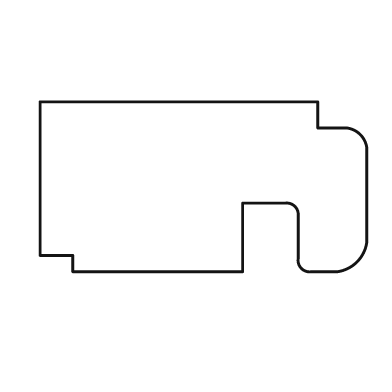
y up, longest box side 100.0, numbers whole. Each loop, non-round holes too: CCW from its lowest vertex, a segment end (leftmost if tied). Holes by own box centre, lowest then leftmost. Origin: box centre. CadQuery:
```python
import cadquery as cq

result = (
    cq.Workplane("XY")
    .moveTo(-40.0, -26.0)
    .lineTo(12.0, -26.0)
    .lineTo(12.0, -5.0)
    .lineTo(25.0, -5.0)
    .threePointArc((28.0, -6.0), (29.0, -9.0))
    .lineTo(29.0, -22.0)
    .threePointArc((30.0, -25.0), (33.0, -26.0))
    .lineTo(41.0, -26.0)
    .threePointArc((47.0, -23.0), (50.0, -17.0))
    .lineTo(50.0, 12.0)
    .threePointArc((48.0, 16.0), (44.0, 18.0))
    .lineTo(35.0, 18.0)
    .lineTo(35.0, 26.0)
    .lineTo(-50.0, 26.0)
    .lineTo(-50.0, -21.0)
    .lineTo(-40.0, -21.0)
    .close()
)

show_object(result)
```